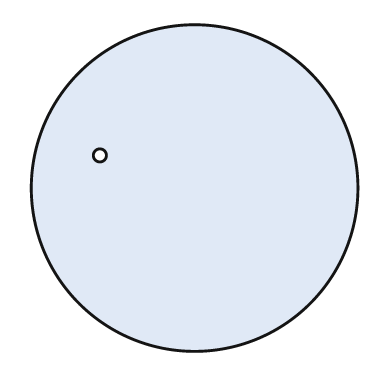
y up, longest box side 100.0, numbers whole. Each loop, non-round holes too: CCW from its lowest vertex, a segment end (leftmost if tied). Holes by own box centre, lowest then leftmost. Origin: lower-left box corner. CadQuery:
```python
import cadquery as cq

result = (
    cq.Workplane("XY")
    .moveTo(50.0, 50.0)
    .circle(50.0)
    .moveTo(21.0, 60.0)
    .circle(2.0)
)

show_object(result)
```